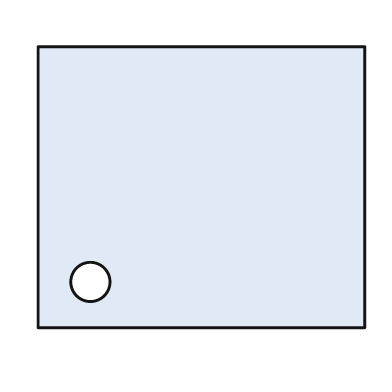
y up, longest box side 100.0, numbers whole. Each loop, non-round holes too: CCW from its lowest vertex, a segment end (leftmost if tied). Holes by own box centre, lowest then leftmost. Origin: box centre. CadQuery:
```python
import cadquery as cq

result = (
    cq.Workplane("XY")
    .moveTo(-50.0, -43.0)
    .lineTo(50.0, -43.0)
    .lineTo(50.0, 43.0)
    .lineTo(-50.0, 43.0)
    .close()
    .moveTo(-34.0, -29.0)
    .circle(6.0)
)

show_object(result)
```